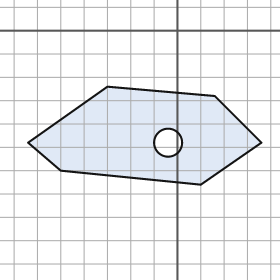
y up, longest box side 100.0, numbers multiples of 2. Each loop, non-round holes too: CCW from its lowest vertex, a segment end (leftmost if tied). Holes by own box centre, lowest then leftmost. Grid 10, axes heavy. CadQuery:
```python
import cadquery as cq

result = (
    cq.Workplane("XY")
    .moveTo(10.0, -66.0)
    .lineTo(36.0, -48.0)
    .lineTo(16.0, -28.0)
    .lineTo(-30.0, -24.0)
    .lineTo(-64.0, -48.0)
    .lineTo(-50.0, -60.0)
    .close()
    .moveTo(-4.0, -48.0)
    .circle(6.0)
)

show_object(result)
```